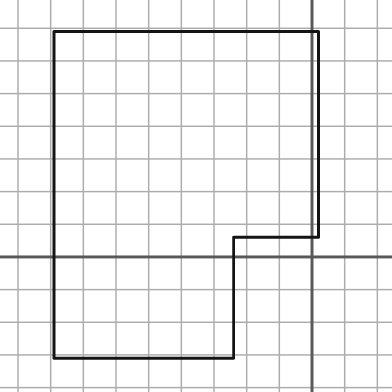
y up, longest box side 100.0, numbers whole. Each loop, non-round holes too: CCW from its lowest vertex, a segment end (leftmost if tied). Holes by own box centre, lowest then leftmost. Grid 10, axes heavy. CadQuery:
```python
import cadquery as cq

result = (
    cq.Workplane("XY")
    .moveTo(-79.0, -31.0)
    .lineTo(-24.0, -31.0)
    .lineTo(-24.0, 6.0)
    .lineTo(2.0, 6.0)
    .lineTo(2.0, 69.0)
    .lineTo(-79.0, 69.0)
    .close()
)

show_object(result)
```